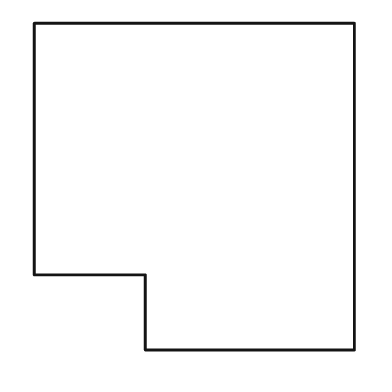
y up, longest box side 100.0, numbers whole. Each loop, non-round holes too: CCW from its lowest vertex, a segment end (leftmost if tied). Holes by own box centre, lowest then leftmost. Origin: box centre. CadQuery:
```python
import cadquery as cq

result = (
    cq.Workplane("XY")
    .moveTo(-15.0, -50.0)
    .lineTo(49.0, -50.0)
    .lineTo(49.0, 50.0)
    .lineTo(-49.0, 50.0)
    .lineTo(-49.0, -27.0)
    .lineTo(-15.0, -27.0)
    .close()
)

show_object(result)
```